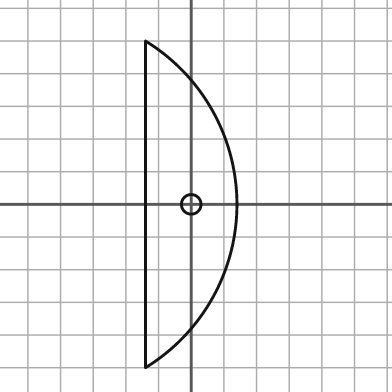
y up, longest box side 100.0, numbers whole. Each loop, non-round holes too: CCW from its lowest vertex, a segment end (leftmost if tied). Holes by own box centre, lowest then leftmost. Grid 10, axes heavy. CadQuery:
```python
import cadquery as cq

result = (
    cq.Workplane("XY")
    .moveTo(-14.0, -50.0)
    .threePointArc((14.0, 0.0), (-14.0, 50.0))
    .close()
    .moveTo(0.0, 0.0)
    .circle(3.0)
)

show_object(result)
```